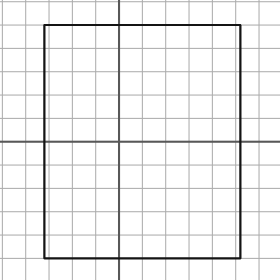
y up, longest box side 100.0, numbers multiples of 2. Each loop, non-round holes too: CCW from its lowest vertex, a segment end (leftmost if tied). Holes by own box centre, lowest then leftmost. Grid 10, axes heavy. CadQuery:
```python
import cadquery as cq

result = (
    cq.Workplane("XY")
    .moveTo(-32.0, -50.0)
    .lineTo(52.0, -50.0)
    .lineTo(52.0, 50.0)
    .lineTo(-32.0, 50.0)
    .close()
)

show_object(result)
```